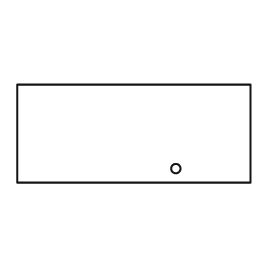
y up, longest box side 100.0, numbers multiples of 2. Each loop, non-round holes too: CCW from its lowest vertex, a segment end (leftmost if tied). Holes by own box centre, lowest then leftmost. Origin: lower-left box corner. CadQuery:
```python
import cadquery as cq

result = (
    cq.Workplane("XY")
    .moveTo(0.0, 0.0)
    .lineTo(100.0, 0.0)
    .lineTo(100.0, 42.0)
    .lineTo(0.0, 42.0)
    .close()
    .moveTo(68.0, 6.0)
    .circle(2.0)
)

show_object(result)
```